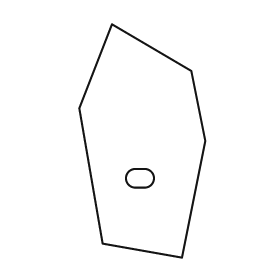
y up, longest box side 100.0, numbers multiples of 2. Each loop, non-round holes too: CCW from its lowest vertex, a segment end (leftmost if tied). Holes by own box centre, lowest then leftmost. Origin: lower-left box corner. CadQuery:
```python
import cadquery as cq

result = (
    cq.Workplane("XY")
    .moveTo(44.0, 0.0)
    .lineTo(54.0, 50.0)
    .lineTo(48.0, 80.0)
    .lineTo(14.0, 100.0)
    .lineTo(0.0, 64.0)
    .lineTo(10.0, 6.0)
    .close()
    .moveTo(24.0, 30.0)
    .lineTo(28.0, 30.0)
    .threePointArc((32.0, 34.0), (28.0, 38.0))
    .lineTo(24.0, 38.0)
    .threePointArc((20.0, 34.0), (24.0, 30.0))
    .close()
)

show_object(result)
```